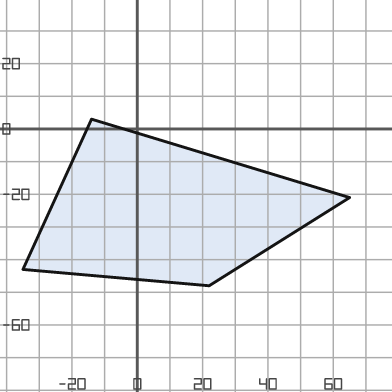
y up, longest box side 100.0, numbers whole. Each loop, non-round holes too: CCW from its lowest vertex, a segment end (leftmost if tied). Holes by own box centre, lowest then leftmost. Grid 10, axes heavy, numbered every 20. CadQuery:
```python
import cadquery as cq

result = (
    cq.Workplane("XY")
    .moveTo(22.0, -48.0)
    .lineTo(65.0, -21.0)
    .lineTo(-14.0, 3.0)
    .lineTo(-35.0, -43.0)
    .close()
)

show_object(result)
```